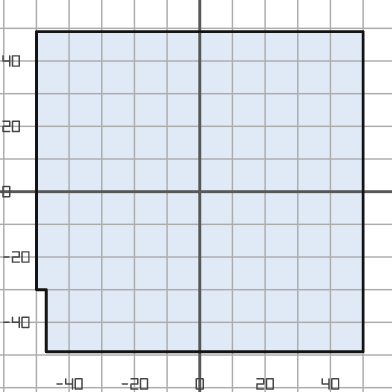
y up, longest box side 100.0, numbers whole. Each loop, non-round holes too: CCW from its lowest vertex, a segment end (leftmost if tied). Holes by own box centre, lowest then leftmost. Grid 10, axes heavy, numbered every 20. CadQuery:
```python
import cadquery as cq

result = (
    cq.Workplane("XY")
    .moveTo(-47.0, -49.0)
    .lineTo(50.0, -49.0)
    .lineTo(50.0, 49.0)
    .lineTo(-50.0, 49.0)
    .lineTo(-50.0, -30.0)
    .lineTo(-47.0, -30.0)
    .close()
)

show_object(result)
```